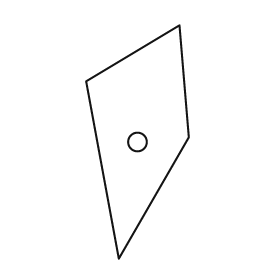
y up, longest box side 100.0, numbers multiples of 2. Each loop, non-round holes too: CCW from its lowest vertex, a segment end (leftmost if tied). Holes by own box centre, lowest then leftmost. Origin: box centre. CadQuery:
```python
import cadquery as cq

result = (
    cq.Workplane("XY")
    .moveTo(-8.0, -50.0)
    .lineTo(22.0, 2.0)
    .lineTo(18.0, 50.0)
    .lineTo(-22.0, 26.0)
    .close()
    .moveTo(0.0, 0.0)
    .circle(4.0)
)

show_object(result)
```